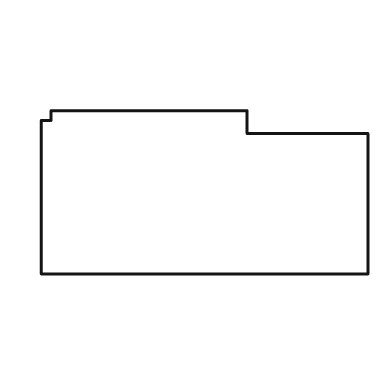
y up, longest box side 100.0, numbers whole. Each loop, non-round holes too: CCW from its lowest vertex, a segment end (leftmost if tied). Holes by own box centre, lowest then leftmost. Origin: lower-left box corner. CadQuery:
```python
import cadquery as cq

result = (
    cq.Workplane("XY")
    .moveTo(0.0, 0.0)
    .lineTo(100.0, 0.0)
    .lineTo(100.0, 43.0)
    .lineTo(63.0, 43.0)
    .lineTo(63.0, 50.0)
    .lineTo(3.0, 50.0)
    .lineTo(3.0, 47.0)
    .lineTo(0.0, 47.0)
    .close()
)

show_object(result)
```